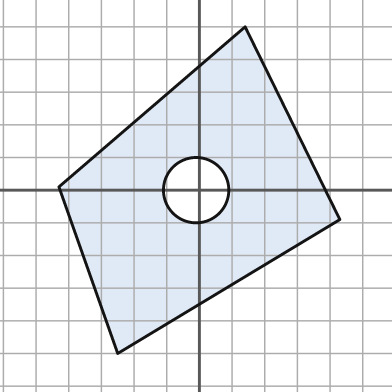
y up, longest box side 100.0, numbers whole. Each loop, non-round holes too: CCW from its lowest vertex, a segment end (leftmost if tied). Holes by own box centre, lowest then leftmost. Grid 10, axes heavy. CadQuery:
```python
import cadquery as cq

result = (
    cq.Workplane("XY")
    .moveTo(-25.0, -50.0)
    .lineTo(43.0, -9.0)
    .lineTo(14.0, 50.0)
    .lineTo(-43.0, 1.0)
    .close()
    .moveTo(-1.0, 0.0)
    .circle(10.0)
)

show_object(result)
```